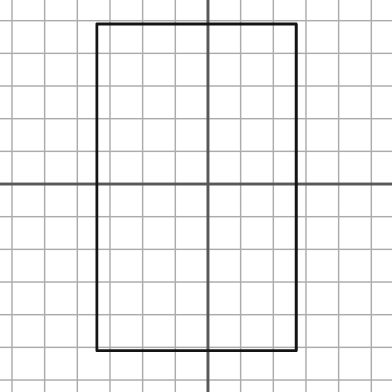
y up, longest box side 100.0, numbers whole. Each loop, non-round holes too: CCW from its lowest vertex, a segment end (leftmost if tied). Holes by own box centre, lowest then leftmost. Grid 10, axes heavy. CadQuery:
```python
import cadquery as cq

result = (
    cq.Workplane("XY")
    .moveTo(-34.0, -51.0)
    .lineTo(27.0, -51.0)
    .lineTo(27.0, 49.0)
    .lineTo(-34.0, 49.0)
    .close()
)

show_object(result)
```